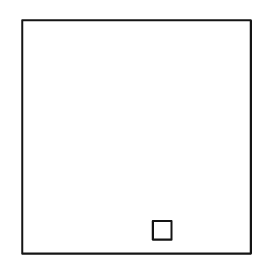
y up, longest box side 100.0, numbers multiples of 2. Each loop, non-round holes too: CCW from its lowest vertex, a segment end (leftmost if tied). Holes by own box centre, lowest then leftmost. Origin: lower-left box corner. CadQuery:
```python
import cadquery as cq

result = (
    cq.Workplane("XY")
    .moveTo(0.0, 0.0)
    .lineTo(98.0, 0.0)
    .lineTo(98.0, 100.0)
    .lineTo(0.0, 100.0)
    .close()
    .moveTo(56.0, 6.0)
    .lineTo(64.0, 6.0)
    .lineTo(64.0, 14.0)
    .lineTo(56.0, 14.0)
    .close()
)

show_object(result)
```